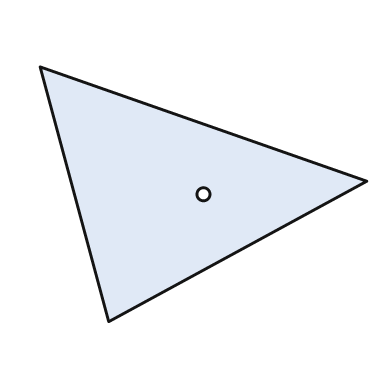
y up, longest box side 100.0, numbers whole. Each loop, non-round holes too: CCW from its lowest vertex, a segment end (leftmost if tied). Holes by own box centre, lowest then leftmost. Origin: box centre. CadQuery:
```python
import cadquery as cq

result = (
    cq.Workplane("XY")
    .moveTo(-29.0, -39.0)
    .lineTo(50.0, 4.0)
    .lineTo(-50.0, 39.0)
    .close()
    .moveTo(0.0, 0.0)
    .circle(2.0)
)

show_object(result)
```